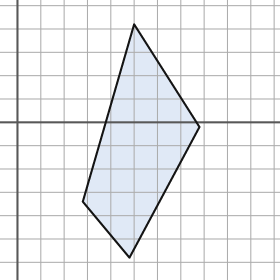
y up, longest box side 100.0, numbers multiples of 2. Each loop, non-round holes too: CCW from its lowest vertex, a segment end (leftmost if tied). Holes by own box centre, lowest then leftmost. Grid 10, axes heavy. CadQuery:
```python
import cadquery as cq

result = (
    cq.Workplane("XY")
    .moveTo(48.0, -58.0)
    .lineTo(78.0, -2.0)
    .lineTo(50.0, 42.0)
    .lineTo(28.0, -34.0)
    .close()
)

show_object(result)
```